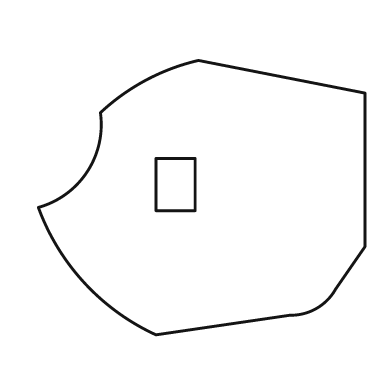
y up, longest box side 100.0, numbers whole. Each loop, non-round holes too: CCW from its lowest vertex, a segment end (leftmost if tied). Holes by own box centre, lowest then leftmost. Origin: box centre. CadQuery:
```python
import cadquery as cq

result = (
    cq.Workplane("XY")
    .moveTo(-14.0, -42.0)
    .lineTo(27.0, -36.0)
    .threePointArc((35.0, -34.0), (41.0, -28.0))
    .lineTo(50.0, -15.0)
    .lineTo(50.0, 32.0)
    .lineTo(-1.0, 42.0)
    .threePointArc((-17.0, 36.0), (-31.0, 26.0))
    .threePointArc((-35.0, 8.0), (-50.0, -3.0))
    .threePointArc((-36.0, -26.0), (-14.0, -42.0))
    .close()
    .moveTo(-14.0, -4.0)
    .lineTo(-2.0, -4.0)
    .lineTo(-2.0, 12.0)
    .lineTo(-14.0, 12.0)
    .close()
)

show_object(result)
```